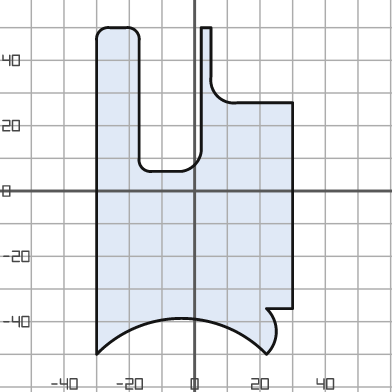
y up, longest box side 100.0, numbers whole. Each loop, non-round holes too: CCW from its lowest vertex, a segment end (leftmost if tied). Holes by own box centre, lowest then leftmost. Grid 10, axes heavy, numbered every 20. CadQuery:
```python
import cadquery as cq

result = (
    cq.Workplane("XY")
    .moveTo(-30.0, -50.0)
    .threePointArc((-4.0, -39.0), (22.0, -50.0))
    .threePointArc((25.0, -43.0), (22.0, -36.0))
    .lineTo(30.0, -36.0)
    .lineTo(30.0, 27.0)
    .lineTo(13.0, 27.0)
    .threePointArc((7.0, 29.0), (5.0, 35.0))
    .lineTo(5.0, 50.0)
    .lineTo(2.0, 50.0)
    .lineTo(2.0, 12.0)
    .threePointArc((0.0, 8.0), (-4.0, 6.0))
    .lineTo(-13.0, 6.0)
    .threePointArc((-16.0, 7.0), (-17.0, 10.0))
    .lineTo(-17.0, 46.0)
    .threePointArc((-18.0, 49.0), (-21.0, 50.0))
    .lineTo(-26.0, 50.0)
    .threePointArc((-29.0, 49.0), (-30.0, 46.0))
    .close()
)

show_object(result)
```